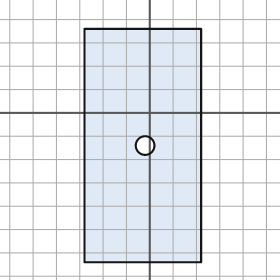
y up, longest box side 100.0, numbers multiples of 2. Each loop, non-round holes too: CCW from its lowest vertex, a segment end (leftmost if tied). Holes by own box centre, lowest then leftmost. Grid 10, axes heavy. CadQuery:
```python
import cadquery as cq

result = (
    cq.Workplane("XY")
    .moveTo(-28.0, -64.0)
    .lineTo(22.0, -64.0)
    .lineTo(22.0, 36.0)
    .lineTo(-28.0, 36.0)
    .close()
    .moveTo(-2.0, -14.0)
    .circle(4.0)
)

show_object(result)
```